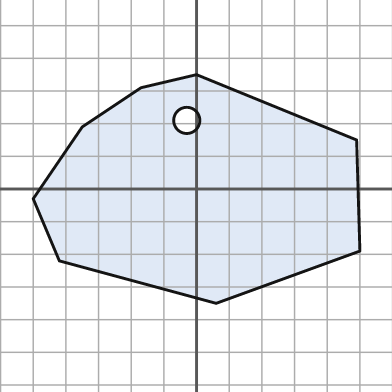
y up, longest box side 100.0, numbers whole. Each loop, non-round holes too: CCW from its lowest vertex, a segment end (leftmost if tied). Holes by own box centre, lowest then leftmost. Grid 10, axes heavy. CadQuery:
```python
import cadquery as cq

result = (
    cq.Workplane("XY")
    .moveTo(6.0, -35.0)
    .lineTo(50.0, -19.0)
    .lineTo(49.0, 15.0)
    .lineTo(0.0, 35.0)
    .lineTo(-17.0, 31.0)
    .lineTo(-35.0, 19.0)
    .lineTo(-50.0, -3.0)
    .lineTo(-42.0, -22.0)
    .close()
    .moveTo(-3.0, 21.0)
    .circle(4.0)
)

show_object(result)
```